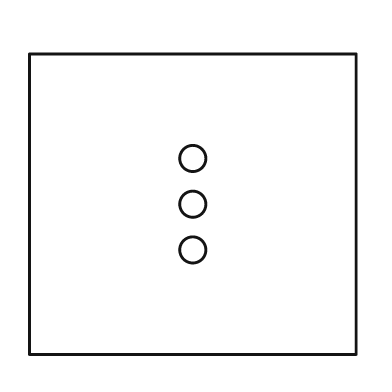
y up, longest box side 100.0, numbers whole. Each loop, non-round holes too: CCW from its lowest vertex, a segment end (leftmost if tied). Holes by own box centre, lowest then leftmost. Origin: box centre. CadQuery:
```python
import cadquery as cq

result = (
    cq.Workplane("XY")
    .moveTo(-50.0, -46.0)
    .lineTo(50.0, -46.0)
    .lineTo(50.0, 46.0)
    .lineTo(-50.0, 46.0)
    .close()
    .moveTo(0.0, -14.0)
    .circle(4.0)
    .moveTo(0.0, 0.0)
    .circle(4.0)
    .moveTo(0.0, 14.0)
    .circle(4.0)
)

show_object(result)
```